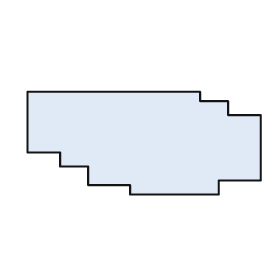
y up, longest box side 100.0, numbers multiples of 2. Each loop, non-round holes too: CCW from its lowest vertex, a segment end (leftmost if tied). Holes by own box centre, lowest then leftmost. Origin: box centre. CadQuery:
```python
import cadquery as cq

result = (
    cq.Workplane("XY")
    .moveTo(-6.0, -22.0)
    .lineTo(32.0, -22.0)
    .lineTo(32.0, -16.0)
    .lineTo(50.0, -16.0)
    .lineTo(50.0, 12.0)
    .lineTo(36.0, 12.0)
    .lineTo(36.0, 18.0)
    .lineTo(24.0, 18.0)
    .lineTo(24.0, 22.0)
    .lineTo(-50.0, 22.0)
    .lineTo(-50.0, -4.0)
    .lineTo(-36.0, -4.0)
    .lineTo(-36.0, -10.0)
    .lineTo(-24.0, -10.0)
    .lineTo(-24.0, -18.0)
    .lineTo(-6.0, -18.0)
    .close()
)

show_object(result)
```